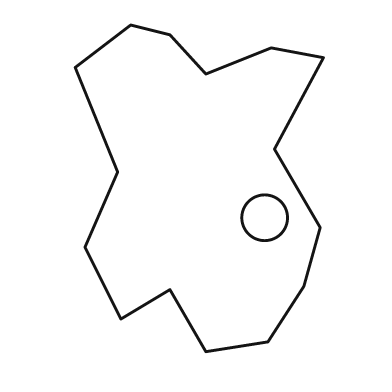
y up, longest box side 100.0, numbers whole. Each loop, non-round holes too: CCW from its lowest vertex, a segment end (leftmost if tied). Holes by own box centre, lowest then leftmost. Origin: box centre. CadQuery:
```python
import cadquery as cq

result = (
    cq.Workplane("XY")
    .moveTo(2.0, -50.0)
    .lineTo(21.0, -47.0)
    .lineTo(32.0, -30.0)
    .lineTo(37.0, -12.0)
    .lineTo(23.0, 12.0)
    .lineTo(38.0, 40.0)
    .lineTo(22.0, 43.0)
    .lineTo(2.0, 35.0)
    .lineTo(-9.0, 47.0)
    .lineTo(-21.0, 50.0)
    .lineTo(-38.0, 37.0)
    .lineTo(-25.0, 5.0)
    .lineTo(-35.0, -18.0)
    .lineTo(-24.0, -40.0)
    .lineTo(-9.0, -31.0)
    .close()
    .moveTo(20.0, -9.0)
    .circle(7.0)
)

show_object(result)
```